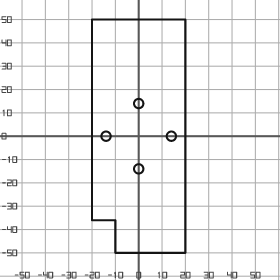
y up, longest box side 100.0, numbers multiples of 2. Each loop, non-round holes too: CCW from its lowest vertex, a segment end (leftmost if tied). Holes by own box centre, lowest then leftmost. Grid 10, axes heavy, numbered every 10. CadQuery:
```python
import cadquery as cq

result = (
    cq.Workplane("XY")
    .moveTo(-10.0, -50.0)
    .lineTo(20.0, -50.0)
    .lineTo(20.0, 50.0)
    .lineTo(-20.0, 50.0)
    .lineTo(-20.0, -36.0)
    .lineTo(-10.0, -36.0)
    .close()
    .moveTo(0.0, -14.0)
    .circle(2.0)
    .moveTo(-14.0, 0.0)
    .circle(2.0)
    .moveTo(14.0, 0.0)
    .circle(2.0)
    .moveTo(0.0, 14.0)
    .circle(2.0)
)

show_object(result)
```